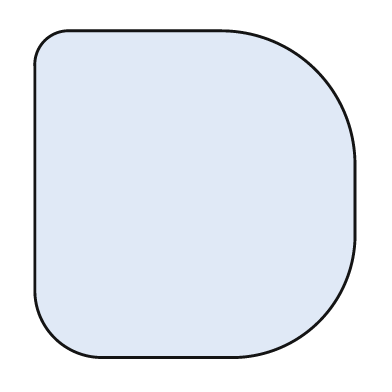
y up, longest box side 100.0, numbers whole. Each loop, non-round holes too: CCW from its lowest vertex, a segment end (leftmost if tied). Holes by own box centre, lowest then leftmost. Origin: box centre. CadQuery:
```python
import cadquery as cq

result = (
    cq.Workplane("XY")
    .moveTo(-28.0, -50.0)
    .lineTo(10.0, -50.0)
    .threePointArc((38.0, -39.0), (49.0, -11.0))
    .lineTo(49.0, 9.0)
    .threePointArc((37.0, 38.0), (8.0, 50.0))
    .lineTo(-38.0, 50.0)
    .threePointArc((-46.0, 47.0), (-49.0, 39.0))
    .lineTo(-49.0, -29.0)
    .threePointArc((-43.0, -44.0), (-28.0, -50.0))
    .close()
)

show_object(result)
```